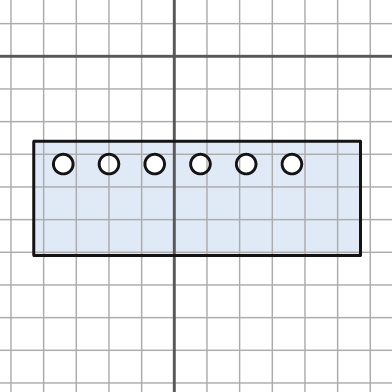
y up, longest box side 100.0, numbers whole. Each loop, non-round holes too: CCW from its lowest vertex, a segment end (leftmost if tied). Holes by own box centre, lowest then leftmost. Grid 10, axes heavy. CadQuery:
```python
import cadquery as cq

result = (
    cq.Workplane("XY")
    .moveTo(-43.0, -61.0)
    .lineTo(57.0, -61.0)
    .lineTo(57.0, -26.0)
    .lineTo(-43.0, -26.0)
    .close()
    .moveTo(-34.0, -33.0)
    .circle(3.0)
    .moveTo(-20.0, -33.0)
    .circle(3.0)
    .moveTo(-6.0, -33.0)
    .circle(3.0)
    .moveTo(8.0, -33.0)
    .circle(3.0)
    .moveTo(22.0, -33.0)
    .circle(3.0)
    .moveTo(36.0, -33.0)
    .circle(3.0)
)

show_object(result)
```